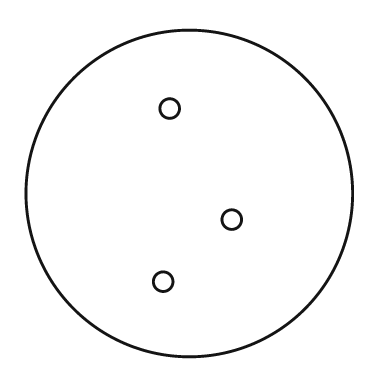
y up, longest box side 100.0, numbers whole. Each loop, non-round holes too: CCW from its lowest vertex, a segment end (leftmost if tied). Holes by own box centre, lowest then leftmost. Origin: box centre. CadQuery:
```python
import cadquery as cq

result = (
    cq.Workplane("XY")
    .moveTo(0.0, 0.0)
    .circle(50.0)
    .moveTo(-8.0, -27.0)
    .circle(3.0)
    .moveTo(13.0, -8.0)
    .circle(3.0)
    .moveTo(-6.0, 26.0)
    .circle(3.0)
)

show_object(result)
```